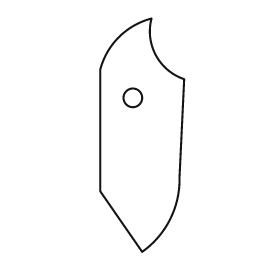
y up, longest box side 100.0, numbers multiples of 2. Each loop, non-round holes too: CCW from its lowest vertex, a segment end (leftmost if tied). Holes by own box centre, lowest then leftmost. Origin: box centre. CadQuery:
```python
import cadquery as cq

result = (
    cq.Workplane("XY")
    .moveTo(0.0, -50.0)
    .threePointArc((12.0, -36.0), (16.0, -18.0))
    .lineTo(18.0, 24.0)
    .threePointArc((6.0, 34.0), (4.0, 50.0))
    .threePointArc((-10.0, 42.0), (-18.0, 28.0))
    .lineTo(-18.0, -24.0)
    .close()
    .moveTo(-4.0, 16.0)
    .circle(4.0)
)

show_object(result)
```